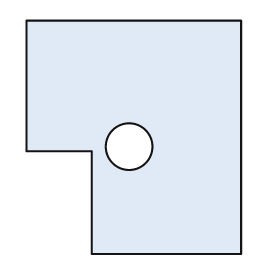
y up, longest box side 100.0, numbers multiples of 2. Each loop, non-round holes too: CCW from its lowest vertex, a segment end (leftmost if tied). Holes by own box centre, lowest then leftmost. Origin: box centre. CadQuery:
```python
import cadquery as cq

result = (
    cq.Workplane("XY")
    .moveTo(-18.0, -50.0)
    .lineTo(46.0, -50.0)
    .lineTo(46.0, 50.0)
    .lineTo(-46.0, 50.0)
    .lineTo(-46.0, -6.0)
    .lineTo(-18.0, -6.0)
    .close()
    .moveTo(-2.0, -4.0)
    .circle(10.0)
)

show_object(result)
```